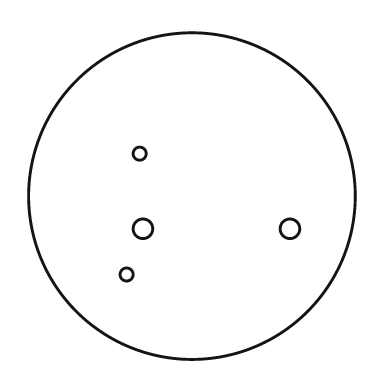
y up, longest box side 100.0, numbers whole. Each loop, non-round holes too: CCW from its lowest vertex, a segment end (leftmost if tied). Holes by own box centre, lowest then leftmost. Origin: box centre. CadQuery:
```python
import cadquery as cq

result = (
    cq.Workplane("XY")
    .moveTo(0.0, 0.0)
    .circle(50.0)
    .moveTo(-20.0, -24.0)
    .circle(2.0)
    .moveTo(-15.0, -10.0)
    .circle(3.0)
    .moveTo(30.0, -10.0)
    .circle(3.0)
    .moveTo(-16.0, 13.0)
    .circle(2.0)
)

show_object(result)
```